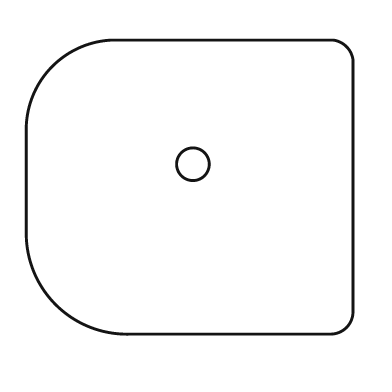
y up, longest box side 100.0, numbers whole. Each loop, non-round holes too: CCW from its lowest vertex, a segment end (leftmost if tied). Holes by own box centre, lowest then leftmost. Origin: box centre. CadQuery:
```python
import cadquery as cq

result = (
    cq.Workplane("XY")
    .moveTo(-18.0, -45.0)
    .lineTo(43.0, -45.0)
    .threePointArc((48.0, -43.0), (50.0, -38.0))
    .lineTo(50.0, 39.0)
    .threePointArc((48.0, 43.0), (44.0, 45.0))
    .lineTo(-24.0, 45.0)
    .threePointArc((-42.0, 37.0), (-50.0, 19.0))
    .lineTo(-50.0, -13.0)
    .threePointArc((-41.0, -36.0), (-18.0, -45.0))
    .close()
    .moveTo(1.0, 7.0)
    .circle(5.0)
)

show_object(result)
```